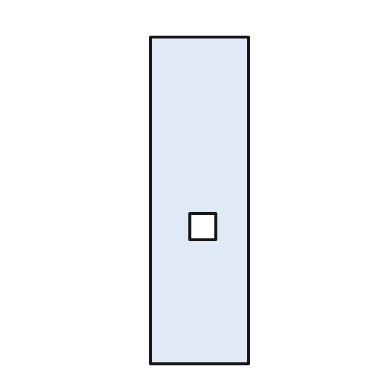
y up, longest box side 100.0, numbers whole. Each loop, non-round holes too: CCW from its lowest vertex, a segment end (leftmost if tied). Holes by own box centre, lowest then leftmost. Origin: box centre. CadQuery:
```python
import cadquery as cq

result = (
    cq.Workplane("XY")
    .moveTo(-15.0, -50.0)
    .lineTo(15.0, -50.0)
    .lineTo(15.0, 50.0)
    .lineTo(-15.0, 50.0)
    .close()
    .moveTo(-3.0, -12.0)
    .lineTo(5.0, -12.0)
    .lineTo(5.0, -4.0)
    .lineTo(-3.0, -4.0)
    .close()
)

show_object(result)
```